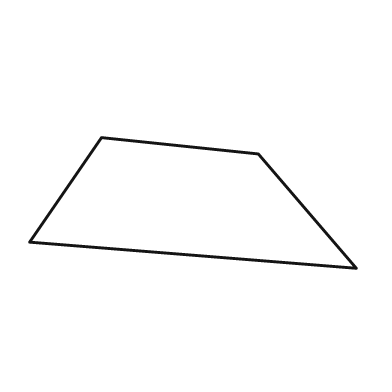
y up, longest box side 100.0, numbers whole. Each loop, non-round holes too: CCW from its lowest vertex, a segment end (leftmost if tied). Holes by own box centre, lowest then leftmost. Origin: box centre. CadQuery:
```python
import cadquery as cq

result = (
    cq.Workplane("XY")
    .moveTo(50.0, -20.0)
    .lineTo(20.0, 15.0)
    .lineTo(-28.0, 20.0)
    .lineTo(-50.0, -12.0)
    .close()
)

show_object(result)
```